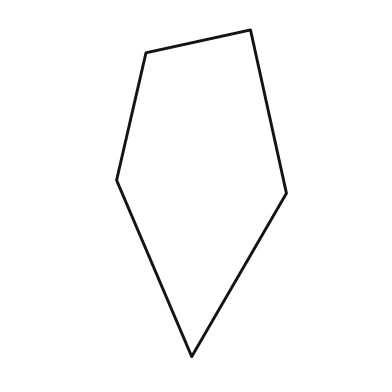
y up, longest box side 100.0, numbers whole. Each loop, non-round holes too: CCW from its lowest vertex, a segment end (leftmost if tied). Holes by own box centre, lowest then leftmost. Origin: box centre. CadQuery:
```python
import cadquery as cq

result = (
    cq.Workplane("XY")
    .moveTo(-3.0, -50.0)
    .lineTo(26.0, 0.0)
    .lineTo(15.0, 50.0)
    .lineTo(-17.0, 43.0)
    .lineTo(-26.0, 4.0)
    .close()
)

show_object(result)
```